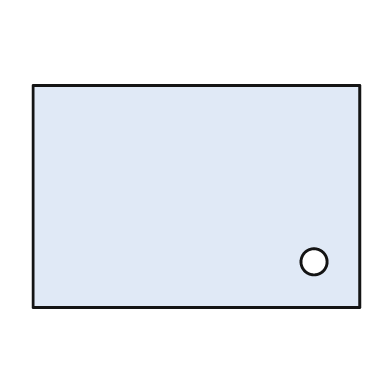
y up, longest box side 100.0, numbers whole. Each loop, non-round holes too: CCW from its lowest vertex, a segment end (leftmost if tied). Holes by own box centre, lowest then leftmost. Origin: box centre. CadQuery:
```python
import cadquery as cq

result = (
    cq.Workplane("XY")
    .moveTo(-50.0, -34.0)
    .lineTo(50.0, -34.0)
    .lineTo(50.0, 34.0)
    .lineTo(-50.0, 34.0)
    .close()
    .moveTo(36.0, -20.0)
    .circle(4.0)
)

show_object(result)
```